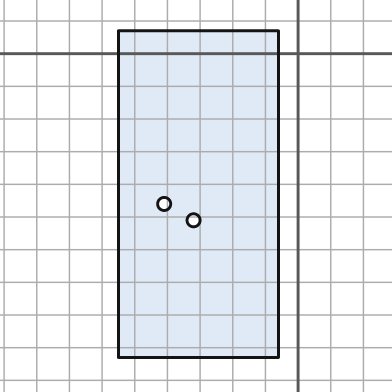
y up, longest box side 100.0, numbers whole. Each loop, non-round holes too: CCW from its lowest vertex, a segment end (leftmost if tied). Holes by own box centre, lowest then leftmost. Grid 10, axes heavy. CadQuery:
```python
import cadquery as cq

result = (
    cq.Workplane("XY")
    .moveTo(-55.0, -93.0)
    .lineTo(-6.0, -93.0)
    .lineTo(-6.0, 7.0)
    .lineTo(-55.0, 7.0)
    .close()
    .moveTo(-32.0, -51.0)
    .circle(2.0)
    .moveTo(-41.0, -46.0)
    .circle(2.0)
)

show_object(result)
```